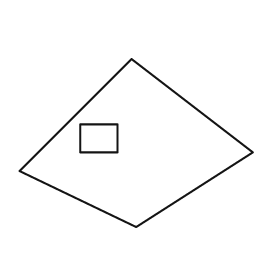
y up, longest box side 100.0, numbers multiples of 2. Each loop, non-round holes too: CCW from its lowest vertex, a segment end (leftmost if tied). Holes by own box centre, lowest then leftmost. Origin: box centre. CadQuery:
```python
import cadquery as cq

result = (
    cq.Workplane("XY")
    .moveTo(0.0, -36.0)
    .lineTo(50.0, -4.0)
    .lineTo(-2.0, 36.0)
    .lineTo(-50.0, -12.0)
    .close()
    .moveTo(-24.0, -4.0)
    .lineTo(-8.0, -4.0)
    .lineTo(-8.0, 8.0)
    .lineTo(-24.0, 8.0)
    .close()
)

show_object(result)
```